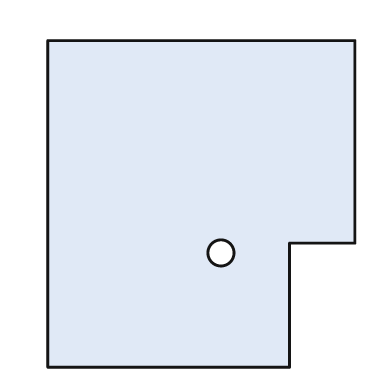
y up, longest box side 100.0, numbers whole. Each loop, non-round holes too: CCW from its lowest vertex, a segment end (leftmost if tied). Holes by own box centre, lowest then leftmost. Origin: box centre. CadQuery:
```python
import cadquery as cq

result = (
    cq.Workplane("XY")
    .moveTo(-47.0, -50.0)
    .lineTo(27.0, -50.0)
    .lineTo(27.0, -12.0)
    .lineTo(47.0, -12.0)
    .lineTo(47.0, 50.0)
    .lineTo(-47.0, 50.0)
    .close()
    .moveTo(6.0, -15.0)
    .circle(4.0)
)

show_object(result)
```